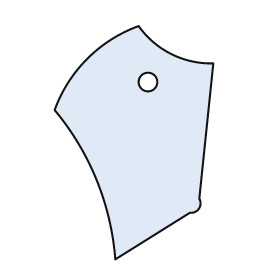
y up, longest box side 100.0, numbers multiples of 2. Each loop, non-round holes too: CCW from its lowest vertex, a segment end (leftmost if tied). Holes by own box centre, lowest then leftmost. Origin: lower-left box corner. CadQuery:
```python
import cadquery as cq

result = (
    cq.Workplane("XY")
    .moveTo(26.0, 0.0)
    .lineTo(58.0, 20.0)
    .threePointArc((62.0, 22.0), (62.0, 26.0))
    .lineTo(68.0, 84.0)
    .threePointArc((50.0, 88.0), (36.0, 100.0))
    .threePointArc((14.0, 86.0), (0.0, 64.0))
    .threePointArc((18.0, 34.0), (26.0, 0.0))
    .close()
    .moveTo(40.0, 76.0)
    .circle(4.0)
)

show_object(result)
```